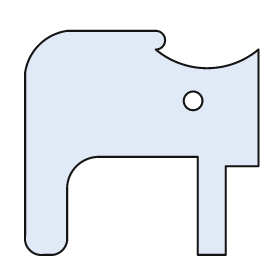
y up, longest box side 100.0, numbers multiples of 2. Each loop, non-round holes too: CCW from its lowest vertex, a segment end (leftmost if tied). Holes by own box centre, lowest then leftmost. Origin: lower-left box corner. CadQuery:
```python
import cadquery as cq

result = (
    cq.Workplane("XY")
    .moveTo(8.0, 0.0)
    .lineTo(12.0, 0.0)
    .threePointArc((16.0, 2.0), (18.0, 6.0))
    .lineTo(18.0, 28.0)
    .threePointArc((22.0, 38.0), (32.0, 42.0))
    .lineTo(74.0, 42.0)
    .lineTo(74.0, 0.0)
    .lineTo(86.0, 0.0)
    .lineTo(86.0, 38.0)
    .lineTo(100.0, 38.0)
    .lineTo(100.0, 88.0)
    .threePointArc((78.0, 80.0), (56.0, 88.0))
    .threePointArc((60.0, 92.0), (56.0, 96.0))
    .lineTo(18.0, 96.0)
    .threePointArc((6.0, 90.0), (0.0, 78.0))
    .lineTo(0.0, 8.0)
    .threePointArc((2.0, 2.0), (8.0, 0.0))
    .close()
    .moveTo(72.0, 66.0)
    .circle(4.0)
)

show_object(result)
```